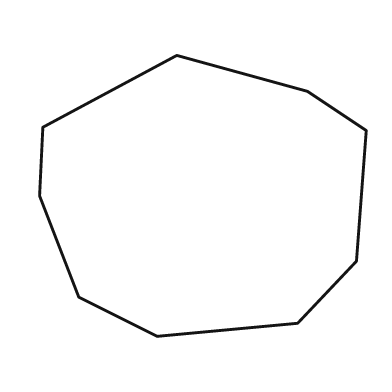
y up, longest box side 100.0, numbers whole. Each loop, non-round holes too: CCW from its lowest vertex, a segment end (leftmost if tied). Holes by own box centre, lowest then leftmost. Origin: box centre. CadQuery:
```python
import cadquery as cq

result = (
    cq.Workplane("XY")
    .moveTo(-14.0, -43.0)
    .lineTo(29.0, -39.0)
    .lineTo(47.0, -20.0)
    .lineTo(50.0, 20.0)
    .lineTo(32.0, 32.0)
    .lineTo(-8.0, 43.0)
    .lineTo(-49.0, 21.0)
    .lineTo(-50.0, 0.0)
    .lineTo(-38.0, -31.0)
    .close()
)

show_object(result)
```